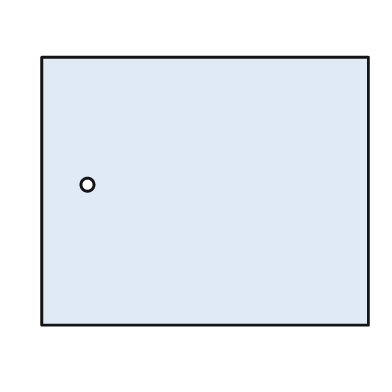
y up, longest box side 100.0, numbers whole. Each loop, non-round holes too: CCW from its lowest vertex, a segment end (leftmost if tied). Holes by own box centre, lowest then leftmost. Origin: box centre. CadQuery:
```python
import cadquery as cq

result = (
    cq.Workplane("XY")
    .moveTo(-50.0, -41.0)
    .lineTo(50.0, -41.0)
    .lineTo(50.0, 41.0)
    .lineTo(-50.0, 41.0)
    .close()
    .moveTo(-36.0, 2.0)
    .circle(2.0)
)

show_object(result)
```